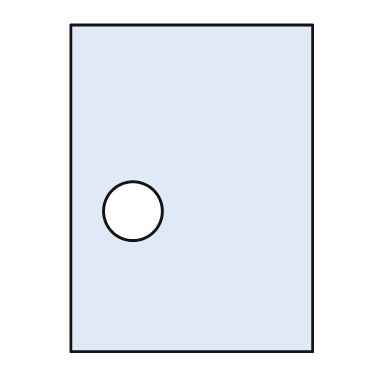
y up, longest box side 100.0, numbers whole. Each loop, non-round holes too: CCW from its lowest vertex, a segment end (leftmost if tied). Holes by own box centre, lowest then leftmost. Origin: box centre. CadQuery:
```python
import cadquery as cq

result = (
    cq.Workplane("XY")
    .moveTo(-37.0, -50.0)
    .lineTo(37.0, -50.0)
    .lineTo(37.0, 50.0)
    .lineTo(-37.0, 50.0)
    .close()
    .moveTo(-18.0, -7.0)
    .circle(9.0)
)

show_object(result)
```